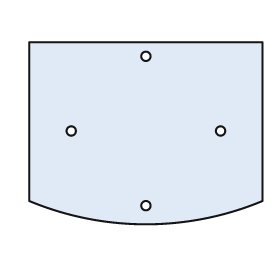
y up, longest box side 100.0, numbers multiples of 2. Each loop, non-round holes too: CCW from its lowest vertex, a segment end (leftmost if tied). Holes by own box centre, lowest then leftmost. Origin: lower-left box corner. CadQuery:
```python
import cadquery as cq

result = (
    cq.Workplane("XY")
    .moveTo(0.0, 10.0)
    .threePointArc((50.0, 0.0), (100.0, 10.0))
    .lineTo(100.0, 78.0)
    .lineTo(0.0, 78.0)
    .close()
    .moveTo(50.0, 8.0)
    .circle(2.0)
    .moveTo(18.0, 40.0)
    .circle(2.0)
    .moveTo(82.0, 40.0)
    .circle(2.0)
    .moveTo(50.0, 72.0)
    .circle(2.0)
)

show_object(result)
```